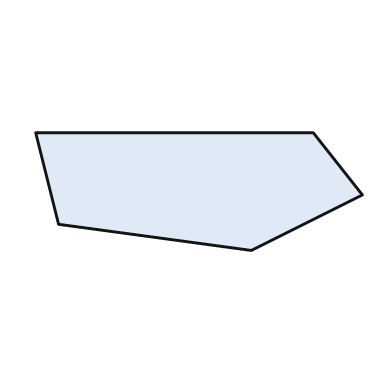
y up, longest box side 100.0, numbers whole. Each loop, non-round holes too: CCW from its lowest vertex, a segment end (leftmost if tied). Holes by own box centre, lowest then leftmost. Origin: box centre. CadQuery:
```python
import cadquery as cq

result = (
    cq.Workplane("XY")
    .moveTo(16.0, -18.0)
    .lineTo(50.0, -1.0)
    .lineTo(35.0, 18.0)
    .lineTo(-50.0, 18.0)
    .lineTo(-43.0, -10.0)
    .close()
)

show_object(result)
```